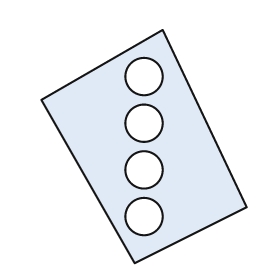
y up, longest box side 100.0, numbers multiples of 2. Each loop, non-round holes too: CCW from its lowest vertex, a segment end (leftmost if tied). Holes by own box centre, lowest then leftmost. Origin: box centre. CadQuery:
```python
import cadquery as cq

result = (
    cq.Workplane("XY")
    .moveTo(-4.0, -50.0)
    .lineTo(44.0, -26.0)
    .lineTo(8.0, 50.0)
    .lineTo(-44.0, 20.0)
    .close()
    .moveTo(0.0, -30.0)
    .circle(8.0)
    .moveTo(0.0, -10.0)
    .circle(8.0)
    .moveTo(0.0, 10.0)
    .circle(8.0)
    .moveTo(0.0, 30.0)
    .circle(8.0)
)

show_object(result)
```